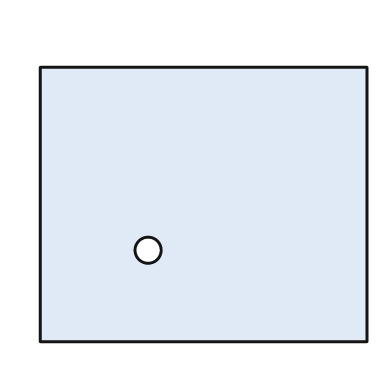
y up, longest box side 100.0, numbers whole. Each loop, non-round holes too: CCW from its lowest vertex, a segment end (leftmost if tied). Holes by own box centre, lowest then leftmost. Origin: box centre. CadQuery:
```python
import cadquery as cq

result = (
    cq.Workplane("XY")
    .moveTo(-50.0, -42.0)
    .lineTo(50.0, -42.0)
    .lineTo(50.0, 42.0)
    .lineTo(-50.0, 42.0)
    .close()
    .moveTo(-17.0, -14.0)
    .circle(4.0)
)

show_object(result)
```